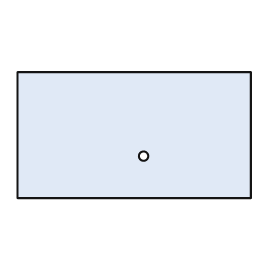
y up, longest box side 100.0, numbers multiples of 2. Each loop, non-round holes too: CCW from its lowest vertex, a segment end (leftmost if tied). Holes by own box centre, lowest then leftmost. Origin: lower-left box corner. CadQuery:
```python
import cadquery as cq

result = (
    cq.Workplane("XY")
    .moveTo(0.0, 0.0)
    .lineTo(100.0, 0.0)
    .lineTo(100.0, 54.0)
    .lineTo(0.0, 54.0)
    .close()
    .moveTo(54.0, 18.0)
    .circle(2.0)
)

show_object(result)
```